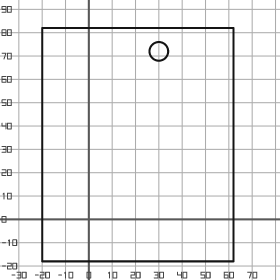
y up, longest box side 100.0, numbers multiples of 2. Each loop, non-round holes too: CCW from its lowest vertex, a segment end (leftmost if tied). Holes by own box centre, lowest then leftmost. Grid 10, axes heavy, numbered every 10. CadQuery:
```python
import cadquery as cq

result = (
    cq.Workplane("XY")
    .moveTo(-20.0, -18.0)
    .lineTo(62.0, -18.0)
    .lineTo(62.0, 82.0)
    .lineTo(-20.0, 82.0)
    .close()
    .moveTo(30.0, 72.0)
    .circle(4.0)
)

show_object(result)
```